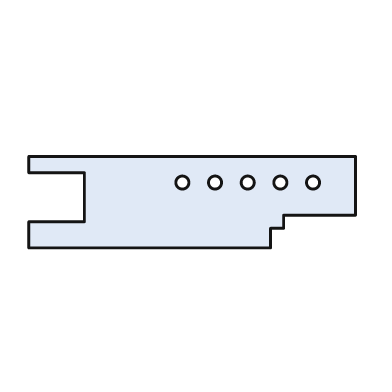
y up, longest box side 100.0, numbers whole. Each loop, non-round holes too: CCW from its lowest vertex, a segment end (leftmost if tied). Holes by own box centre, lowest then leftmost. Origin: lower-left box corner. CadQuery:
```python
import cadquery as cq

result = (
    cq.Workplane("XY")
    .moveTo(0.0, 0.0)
    .lineTo(74.0, 0.0)
    .lineTo(74.0, 6.0)
    .lineTo(78.0, 6.0)
    .lineTo(78.0, 10.0)
    .lineTo(100.0, 10.0)
    .lineTo(100.0, 28.0)
    .lineTo(0.0, 28.0)
    .lineTo(0.0, 23.0)
    .lineTo(17.0, 23.0)
    .lineTo(17.0, 8.0)
    .lineTo(0.0, 8.0)
    .close()
    .moveTo(47.0, 20.0)
    .circle(2.0)
    .moveTo(57.0, 20.0)
    .circle(2.0)
    .moveTo(67.0, 20.0)
    .circle(2.0)
    .moveTo(77.0, 20.0)
    .circle(2.0)
    .moveTo(87.0, 20.0)
    .circle(2.0)
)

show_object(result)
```